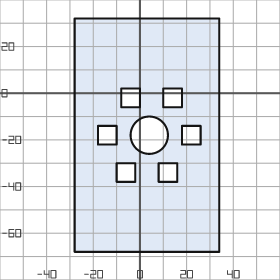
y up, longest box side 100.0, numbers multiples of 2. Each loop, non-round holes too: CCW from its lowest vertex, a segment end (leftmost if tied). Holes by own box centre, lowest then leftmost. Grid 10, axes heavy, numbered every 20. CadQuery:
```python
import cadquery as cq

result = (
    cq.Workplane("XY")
    .moveTo(-28.0, -68.0)
    .lineTo(34.0, -68.0)
    .lineTo(34.0, 32.0)
    .lineTo(-28.0, 32.0)
    .close()
    .moveTo(-10.0, -38.0)
    .lineTo(-2.0, -38.0)
    .lineTo(-2.0, -30.0)
    .lineTo(-10.0, -30.0)
    .close()
    .moveTo(8.0, -38.0)
    .lineTo(16.0, -38.0)
    .lineTo(16.0, -30.0)
    .lineTo(8.0, -30.0)
    .close()
    .moveTo(-18.0, -22.0)
    .lineTo(-10.0, -22.0)
    .lineTo(-10.0, -14.0)
    .lineTo(-18.0, -14.0)
    .close()
    .moveTo(4.0, -18.0)
    .circle(8.0)
    .moveTo(18.0, -22.0)
    .lineTo(26.0, -22.0)
    .lineTo(26.0, -14.0)
    .lineTo(18.0, -14.0)
    .close()
    .moveTo(-8.0, -6.0)
    .lineTo(0.0, -6.0)
    .lineTo(0.0, 2.0)
    .lineTo(-8.0, 2.0)
    .close()
    .moveTo(10.0, -6.0)
    .lineTo(18.0, -6.0)
    .lineTo(18.0, 2.0)
    .lineTo(10.0, 2.0)
    .close()
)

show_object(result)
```